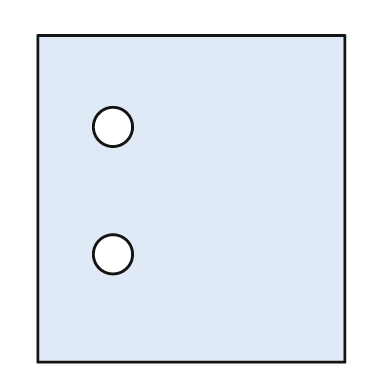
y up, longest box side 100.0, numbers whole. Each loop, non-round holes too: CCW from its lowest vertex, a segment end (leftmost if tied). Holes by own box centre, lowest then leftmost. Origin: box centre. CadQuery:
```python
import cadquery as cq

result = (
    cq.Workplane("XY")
    .moveTo(-47.0, -50.0)
    .lineTo(47.0, -50.0)
    .lineTo(47.0, 50.0)
    .lineTo(-47.0, 50.0)
    .close()
    .moveTo(-24.0, -17.0)
    .circle(6.0)
    .moveTo(-24.0, 22.0)
    .circle(6.0)
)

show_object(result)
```